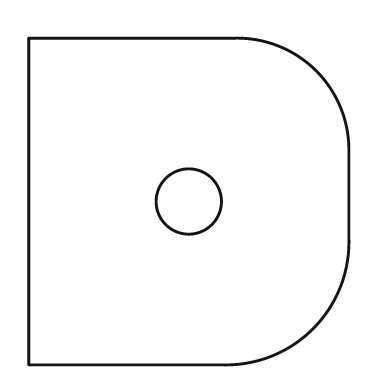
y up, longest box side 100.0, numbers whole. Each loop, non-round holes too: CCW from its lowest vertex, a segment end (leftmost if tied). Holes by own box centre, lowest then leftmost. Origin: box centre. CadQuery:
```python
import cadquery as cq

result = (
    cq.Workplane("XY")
    .moveTo(-49.0, -50.0)
    .lineTo(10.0, -50.0)
    .threePointArc((38.0, -39.0), (49.0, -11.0))
    .lineTo(49.0, 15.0)
    .threePointArc((39.0, 40.0), (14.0, 50.0))
    .lineTo(-49.0, 50.0)
    .close()
    .moveTo(0.0, 0.0)
    .circle(10.0)
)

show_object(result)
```